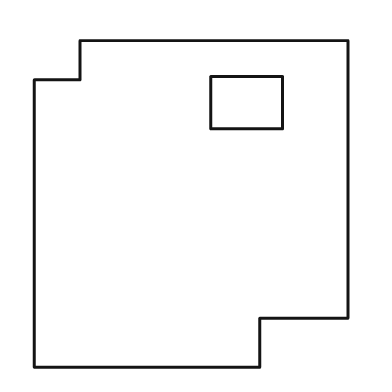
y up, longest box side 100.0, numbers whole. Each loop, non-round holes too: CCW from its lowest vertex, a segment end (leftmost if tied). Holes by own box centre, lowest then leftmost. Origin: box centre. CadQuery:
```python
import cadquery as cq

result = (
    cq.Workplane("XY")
    .moveTo(-48.0, -50.0)
    .lineTo(21.0, -50.0)
    .lineTo(21.0, -35.0)
    .lineTo(48.0, -35.0)
    .lineTo(48.0, 50.0)
    .lineTo(-34.0, 50.0)
    .lineTo(-34.0, 38.0)
    .lineTo(-48.0, 38.0)
    .close()
    .moveTo(6.0, 23.0)
    .lineTo(28.0, 23.0)
    .lineTo(28.0, 39.0)
    .lineTo(6.0, 39.0)
    .close()
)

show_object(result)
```